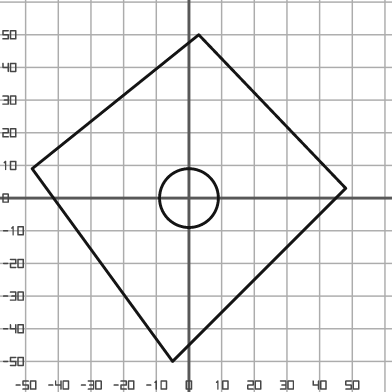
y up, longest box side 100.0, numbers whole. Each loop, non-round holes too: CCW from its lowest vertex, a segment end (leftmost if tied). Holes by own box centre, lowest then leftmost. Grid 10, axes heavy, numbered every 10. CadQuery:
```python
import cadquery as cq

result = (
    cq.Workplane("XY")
    .moveTo(-5.0, -50.0)
    .lineTo(48.0, 3.0)
    .lineTo(3.0, 50.0)
    .lineTo(-48.0, 9.0)
    .close()
    .moveTo(0.0, 0.0)
    .circle(9.0)
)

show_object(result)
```